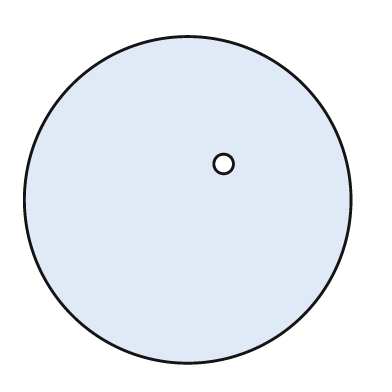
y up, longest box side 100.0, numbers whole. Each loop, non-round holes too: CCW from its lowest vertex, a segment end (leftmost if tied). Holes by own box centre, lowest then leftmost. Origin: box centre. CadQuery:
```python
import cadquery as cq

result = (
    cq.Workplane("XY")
    .moveTo(0.0, 0.0)
    .circle(50.0)
    .moveTo(11.0, 11.0)
    .circle(3.0)
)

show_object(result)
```